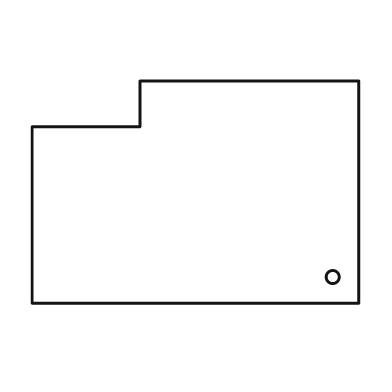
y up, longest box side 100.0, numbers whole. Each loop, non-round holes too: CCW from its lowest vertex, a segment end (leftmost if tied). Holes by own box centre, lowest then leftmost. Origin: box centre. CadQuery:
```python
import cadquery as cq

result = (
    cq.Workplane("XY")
    .moveTo(-50.0, -34.0)
    .lineTo(50.0, -34.0)
    .lineTo(50.0, 34.0)
    .lineTo(-17.0, 34.0)
    .lineTo(-17.0, 20.0)
    .lineTo(-50.0, 20.0)
    .close()
    .moveTo(42.0, -26.0)
    .circle(2.0)
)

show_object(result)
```